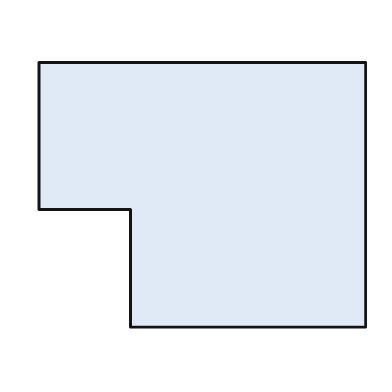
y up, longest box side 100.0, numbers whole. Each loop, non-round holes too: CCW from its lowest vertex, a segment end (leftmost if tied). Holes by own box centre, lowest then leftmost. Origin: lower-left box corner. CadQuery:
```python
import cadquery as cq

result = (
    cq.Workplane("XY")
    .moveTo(28.0, 0.0)
    .lineTo(100.0, 0.0)
    .lineTo(100.0, 81.0)
    .lineTo(0.0, 81.0)
    .lineTo(0.0, 36.0)
    .lineTo(28.0, 36.0)
    .close()
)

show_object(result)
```